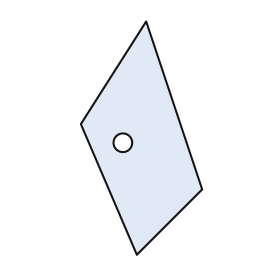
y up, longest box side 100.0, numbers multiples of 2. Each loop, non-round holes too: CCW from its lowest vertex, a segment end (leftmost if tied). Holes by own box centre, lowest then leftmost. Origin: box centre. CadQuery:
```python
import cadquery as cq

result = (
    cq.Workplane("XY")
    .moveTo(-2.0, -50.0)
    .lineTo(26.0, -22.0)
    .lineTo(2.0, 50.0)
    .lineTo(-26.0, 6.0)
    .close()
    .moveTo(-8.0, -2.0)
    .circle(4.0)
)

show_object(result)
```